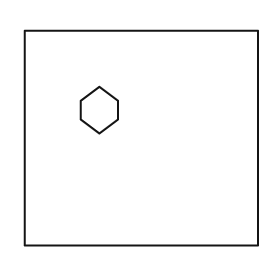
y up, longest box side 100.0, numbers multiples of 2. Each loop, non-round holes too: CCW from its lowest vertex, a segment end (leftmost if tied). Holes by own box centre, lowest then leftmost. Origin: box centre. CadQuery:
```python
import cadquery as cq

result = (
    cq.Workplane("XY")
    .moveTo(-50.0, -46.0)
    .lineTo(50.0, -46.0)
    .lineTo(50.0, 46.0)
    .lineTo(-50.0, 46.0)
    .close()
    .moveTo(-18.0, 2.0)
    .lineTo(-10.0, 8.0)
    .lineTo(-10.0, 16.0)
    .lineTo(-18.0, 22.0)
    .lineTo(-26.0, 16.0)
    .lineTo(-26.0, 8.0)
    .close()
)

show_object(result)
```